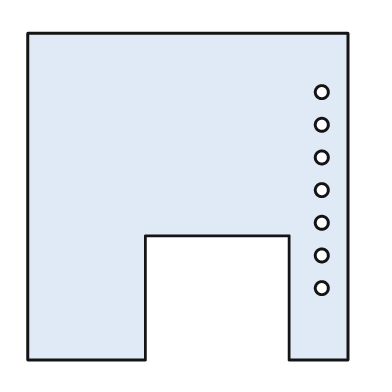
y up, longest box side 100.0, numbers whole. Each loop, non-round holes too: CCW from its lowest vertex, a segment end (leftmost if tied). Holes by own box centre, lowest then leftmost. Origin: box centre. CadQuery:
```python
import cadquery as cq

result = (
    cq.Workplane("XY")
    .moveTo(-49.0, -50.0)
    .lineTo(-13.0, -50.0)
    .lineTo(-13.0, -12.0)
    .lineTo(31.0, -12.0)
    .lineTo(31.0, -50.0)
    .lineTo(49.0, -50.0)
    .lineTo(49.0, 50.0)
    .lineTo(-49.0, 50.0)
    .close()
    .moveTo(41.0, -28.0)
    .circle(2.0)
    .moveTo(41.0, -18.0)
    .circle(2.0)
    .moveTo(41.0, -8.0)
    .circle(2.0)
    .moveTo(41.0, 2.0)
    .circle(2.0)
    .moveTo(41.0, 12.0)
    .circle(2.0)
    .moveTo(41.0, 22.0)
    .circle(2.0)
    .moveTo(41.0, 32.0)
    .circle(2.0)
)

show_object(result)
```